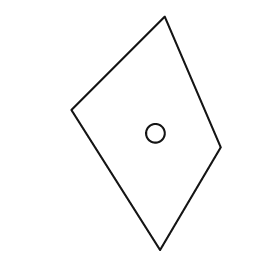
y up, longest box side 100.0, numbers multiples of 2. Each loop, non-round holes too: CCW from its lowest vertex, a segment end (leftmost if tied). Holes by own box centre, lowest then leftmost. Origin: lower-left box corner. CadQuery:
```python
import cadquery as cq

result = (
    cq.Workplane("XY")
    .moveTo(38.0, 0.0)
    .lineTo(64.0, 44.0)
    .lineTo(40.0, 100.0)
    .lineTo(0.0, 60.0)
    .close()
    .moveTo(36.0, 50.0)
    .circle(4.0)
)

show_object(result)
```